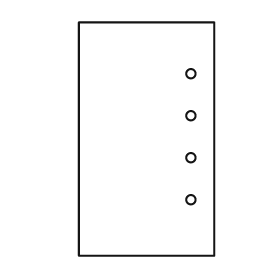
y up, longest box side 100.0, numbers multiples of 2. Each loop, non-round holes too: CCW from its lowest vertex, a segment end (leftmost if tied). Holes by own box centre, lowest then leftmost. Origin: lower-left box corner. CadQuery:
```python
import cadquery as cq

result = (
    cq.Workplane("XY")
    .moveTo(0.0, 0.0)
    .lineTo(58.0, 0.0)
    .lineTo(58.0, 100.0)
    .lineTo(0.0, 100.0)
    .close()
    .moveTo(48.0, 24.0)
    .circle(2.0)
    .moveTo(48.0, 42.0)
    .circle(2.0)
    .moveTo(48.0, 60.0)
    .circle(2.0)
    .moveTo(48.0, 78.0)
    .circle(2.0)
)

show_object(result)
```